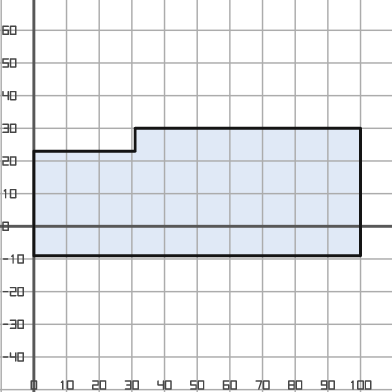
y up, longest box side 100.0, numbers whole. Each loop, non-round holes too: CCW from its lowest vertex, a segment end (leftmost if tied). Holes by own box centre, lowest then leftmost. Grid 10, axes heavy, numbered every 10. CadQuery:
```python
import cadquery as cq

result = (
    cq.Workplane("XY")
    .moveTo(0.0, -9.0)
    .lineTo(100.0, -9.0)
    .lineTo(100.0, 30.0)
    .lineTo(31.0, 30.0)
    .lineTo(31.0, 23.0)
    .lineTo(0.0, 23.0)
    .close()
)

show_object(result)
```